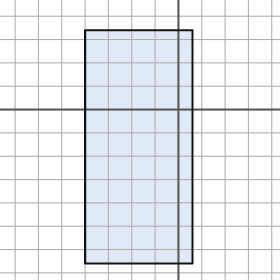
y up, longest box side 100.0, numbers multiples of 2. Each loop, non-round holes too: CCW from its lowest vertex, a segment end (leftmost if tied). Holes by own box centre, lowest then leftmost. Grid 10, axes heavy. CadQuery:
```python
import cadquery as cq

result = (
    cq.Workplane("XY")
    .moveTo(-40.0, -66.0)
    .lineTo(6.0, -66.0)
    .lineTo(6.0, 34.0)
    .lineTo(-40.0, 34.0)
    .close()
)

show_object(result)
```